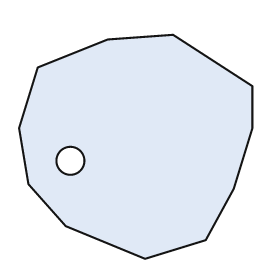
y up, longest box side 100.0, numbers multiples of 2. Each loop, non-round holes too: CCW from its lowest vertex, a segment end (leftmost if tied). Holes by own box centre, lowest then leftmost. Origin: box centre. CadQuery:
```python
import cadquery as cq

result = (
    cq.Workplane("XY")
    .moveTo(4.0, -48.0)
    .lineTo(30.0, -40.0)
    .lineTo(42.0, -18.0)
    .lineTo(50.0, 8.0)
    .lineTo(50.0, 26.0)
    .lineTo(16.0, 48.0)
    .lineTo(-12.0, 46.0)
    .lineTo(-42.0, 34.0)
    .lineTo(-50.0, 8.0)
    .lineTo(-46.0, -16.0)
    .lineTo(-30.0, -34.0)
    .close()
    .moveTo(-28.0, -6.0)
    .circle(6.0)
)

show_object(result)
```